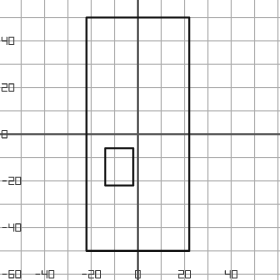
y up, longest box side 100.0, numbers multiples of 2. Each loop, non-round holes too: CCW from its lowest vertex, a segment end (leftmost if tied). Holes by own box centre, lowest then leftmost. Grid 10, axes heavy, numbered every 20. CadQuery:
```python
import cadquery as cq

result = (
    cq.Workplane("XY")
    .moveTo(-22.0, -50.0)
    .lineTo(22.0, -50.0)
    .lineTo(22.0, 50.0)
    .lineTo(-22.0, 50.0)
    .close()
    .moveTo(-14.0, -22.0)
    .lineTo(-2.0, -22.0)
    .lineTo(-2.0, -6.0)
    .lineTo(-14.0, -6.0)
    .close()
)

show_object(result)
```